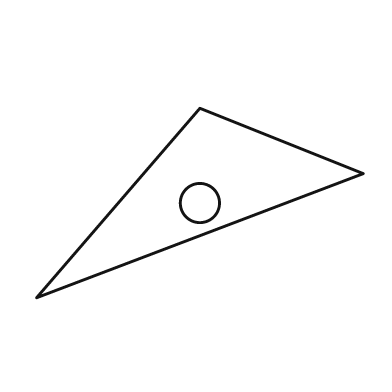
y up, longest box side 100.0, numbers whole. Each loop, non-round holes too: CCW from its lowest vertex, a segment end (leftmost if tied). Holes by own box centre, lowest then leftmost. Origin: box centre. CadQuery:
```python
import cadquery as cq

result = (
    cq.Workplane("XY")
    .moveTo(-50.0, -29.0)
    .lineTo(50.0, 9.0)
    .lineTo(0.0, 29.0)
    .close()
    .moveTo(0.0, 0.0)
    .circle(6.0)
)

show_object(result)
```